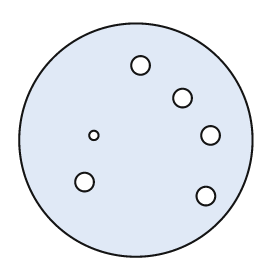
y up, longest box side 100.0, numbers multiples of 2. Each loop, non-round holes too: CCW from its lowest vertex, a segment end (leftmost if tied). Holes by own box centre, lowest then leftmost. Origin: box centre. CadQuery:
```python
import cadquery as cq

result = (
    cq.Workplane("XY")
    .moveTo(0.0, 0.0)
    .circle(50.0)
    .moveTo(30.0, -24.0)
    .circle(4.0)
    .moveTo(-22.0, -18.0)
    .circle(4.0)
    .moveTo(-18.0, 2.0)
    .circle(2.0)
    .moveTo(32.0, 2.0)
    .circle(4.0)
    .moveTo(20.0, 18.0)
    .circle(4.0)
    .moveTo(2.0, 32.0)
    .circle(4.0)
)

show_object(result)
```